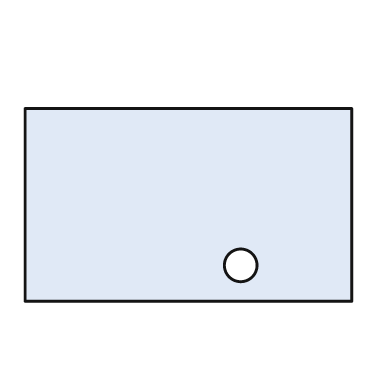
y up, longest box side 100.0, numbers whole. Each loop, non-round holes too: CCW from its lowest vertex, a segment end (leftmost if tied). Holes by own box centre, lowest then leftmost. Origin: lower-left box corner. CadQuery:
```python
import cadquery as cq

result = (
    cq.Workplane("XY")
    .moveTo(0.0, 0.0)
    .lineTo(100.0, 0.0)
    .lineTo(100.0, 59.0)
    .lineTo(0.0, 59.0)
    .close()
    .moveTo(66.0, 11.0)
    .circle(5.0)
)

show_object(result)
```